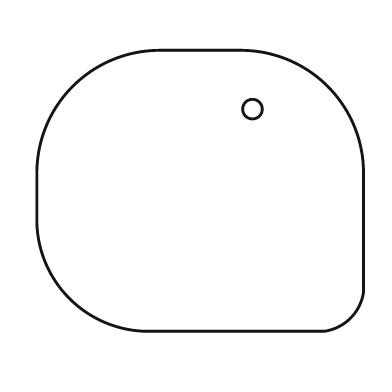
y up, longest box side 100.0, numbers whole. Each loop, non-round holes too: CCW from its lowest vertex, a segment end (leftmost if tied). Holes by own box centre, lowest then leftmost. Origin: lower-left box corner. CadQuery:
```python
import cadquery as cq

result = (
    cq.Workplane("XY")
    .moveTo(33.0, 0.0)
    .lineTo(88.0, 0.0)
    .threePointArc((96.0, 4.0), (100.0, 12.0))
    .lineTo(100.0, 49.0)
    .threePointArc((89.0, 75.0), (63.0, 86.0))
    .lineTo(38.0, 86.0)
    .threePointArc((11.0, 75.0), (0.0, 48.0))
    .lineTo(0.0, 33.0)
    .threePointArc((10.0, 10.0), (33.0, 0.0))
    .close()
    .moveTo(66.0, 68.0)
    .circle(3.0)
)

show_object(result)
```